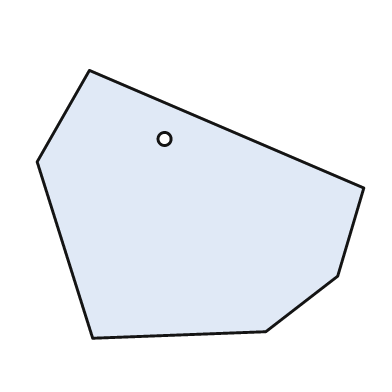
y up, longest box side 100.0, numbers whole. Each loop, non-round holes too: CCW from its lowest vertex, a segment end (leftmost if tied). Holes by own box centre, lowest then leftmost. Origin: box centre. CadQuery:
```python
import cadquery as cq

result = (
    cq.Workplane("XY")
    .moveTo(-33.0, -41.0)
    .lineTo(20.0, -39.0)
    .lineTo(42.0, -22.0)
    .lineTo(50.0, 5.0)
    .lineTo(-34.0, 41.0)
    .lineTo(-50.0, 13.0)
    .close()
    .moveTo(-11.0, 20.0)
    .circle(2.0)
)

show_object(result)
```